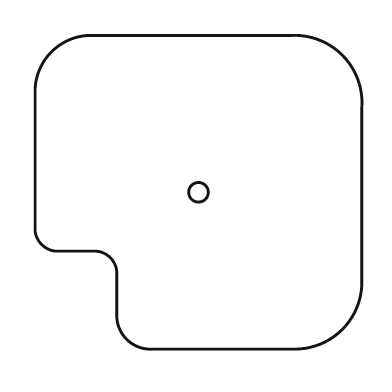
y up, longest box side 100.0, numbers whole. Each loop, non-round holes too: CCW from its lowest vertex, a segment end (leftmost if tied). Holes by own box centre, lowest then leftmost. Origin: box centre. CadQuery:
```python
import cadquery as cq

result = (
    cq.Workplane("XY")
    .moveTo(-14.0, -48.0)
    .lineTo(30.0, -48.0)
    .threePointArc((44.0, -42.0), (50.0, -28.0))
    .lineTo(50.0, 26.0)
    .threePointArc((44.0, 42.0), (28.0, 48.0))
    .lineTo(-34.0, 48.0)
    .threePointArc((-45.0, 43.0), (-50.0, 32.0))
    .lineTo(-50.0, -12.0)
    .threePointArc((-48.0, -16.0), (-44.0, -18.0))
    .lineTo(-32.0, -18.0)
    .threePointArc((-27.0, -20.0), (-25.0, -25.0))
    .lineTo(-25.0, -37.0)
    .threePointArc((-22.0, -45.0), (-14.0, -48.0))
    .close()
    .moveTo(0.0, 0.0)
    .circle(3.0)
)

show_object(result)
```